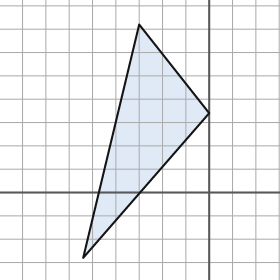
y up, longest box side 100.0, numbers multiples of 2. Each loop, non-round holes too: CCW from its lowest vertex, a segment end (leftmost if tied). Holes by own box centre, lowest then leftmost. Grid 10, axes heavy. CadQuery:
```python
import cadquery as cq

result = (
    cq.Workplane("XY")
    .moveTo(-54.0, -28.0)
    .lineTo(0.0, 34.0)
    .lineTo(-30.0, 72.0)
    .close()
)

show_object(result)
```